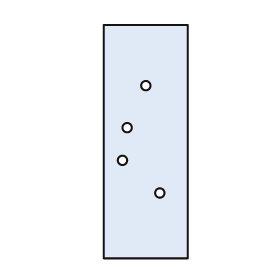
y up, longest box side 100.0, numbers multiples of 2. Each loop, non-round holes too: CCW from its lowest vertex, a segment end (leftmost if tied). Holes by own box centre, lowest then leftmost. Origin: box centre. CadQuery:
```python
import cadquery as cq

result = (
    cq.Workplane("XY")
    .moveTo(-18.0, -50.0)
    .lineTo(18.0, -50.0)
    .lineTo(18.0, 50.0)
    .lineTo(-18.0, 50.0)
    .close()
    .moveTo(6.0, -22.0)
    .circle(2.0)
    .moveTo(-10.0, -8.0)
    .circle(2.0)
    .moveTo(-8.0, 6.0)
    .circle(2.0)
    .moveTo(0.0, 24.0)
    .circle(2.0)
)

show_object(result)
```